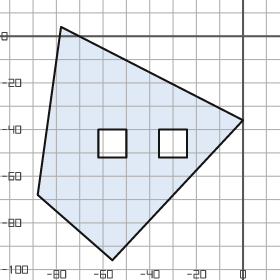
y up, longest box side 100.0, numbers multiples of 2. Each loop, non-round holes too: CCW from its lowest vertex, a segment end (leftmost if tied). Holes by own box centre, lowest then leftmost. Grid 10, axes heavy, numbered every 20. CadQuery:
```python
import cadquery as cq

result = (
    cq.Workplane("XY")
    .moveTo(-56.0, -96.0)
    .lineTo(0.0, -36.0)
    .lineTo(-78.0, 4.0)
    .lineTo(-88.0, -68.0)
    .close()
    .moveTo(-62.0, -52.0)
    .lineTo(-50.0, -52.0)
    .lineTo(-50.0, -40.0)
    .lineTo(-62.0, -40.0)
    .close()
    .moveTo(-36.0, -52.0)
    .lineTo(-24.0, -52.0)
    .lineTo(-24.0, -40.0)
    .lineTo(-36.0, -40.0)
    .close()
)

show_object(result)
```